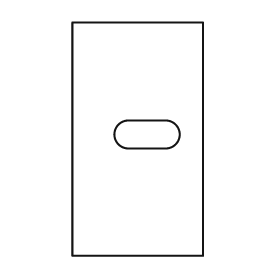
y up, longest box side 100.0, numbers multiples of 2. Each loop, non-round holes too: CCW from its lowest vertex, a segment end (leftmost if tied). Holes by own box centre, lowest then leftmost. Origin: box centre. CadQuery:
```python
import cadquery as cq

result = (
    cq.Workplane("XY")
    .moveTo(-28.0, -50.0)
    .lineTo(28.0, -50.0)
    .lineTo(28.0, 50.0)
    .lineTo(-28.0, 50.0)
    .close()
    .moveTo(-4.0, -4.0)
    .lineTo(12.0, -4.0)
    .threePointArc((18.0, 2.0), (12.0, 8.0))
    .lineTo(-4.0, 8.0)
    .threePointArc((-10.0, 2.0), (-4.0, -4.0))
    .close()
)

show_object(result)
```